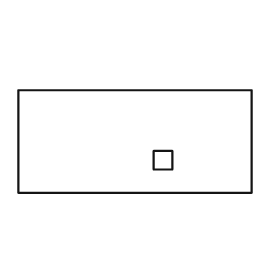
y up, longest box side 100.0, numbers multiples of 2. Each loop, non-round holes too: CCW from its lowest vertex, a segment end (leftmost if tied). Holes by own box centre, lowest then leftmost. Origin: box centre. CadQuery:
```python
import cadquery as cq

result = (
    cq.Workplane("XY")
    .moveTo(-50.0, -22.0)
    .lineTo(50.0, -22.0)
    .lineTo(50.0, 22.0)
    .lineTo(-50.0, 22.0)
    .close()
    .moveTo(8.0, -12.0)
    .lineTo(16.0, -12.0)
    .lineTo(16.0, -4.0)
    .lineTo(8.0, -4.0)
    .close()
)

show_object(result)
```